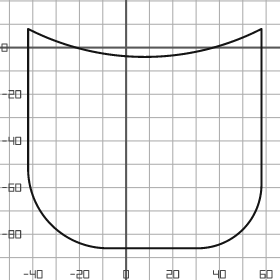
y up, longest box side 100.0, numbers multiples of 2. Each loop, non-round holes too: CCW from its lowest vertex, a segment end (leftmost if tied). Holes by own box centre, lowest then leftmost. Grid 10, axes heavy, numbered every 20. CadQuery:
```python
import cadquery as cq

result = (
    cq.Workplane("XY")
    .moveTo(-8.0, -86.0)
    .lineTo(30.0, -86.0)
    .threePointArc((50.0, -78.0), (58.0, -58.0))
    .lineTo(58.0, 8.0)
    .threePointArc((8.0, -4.0), (-42.0, 8.0))
    .lineTo(-42.0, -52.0)
    .threePointArc((-32.0, -76.0), (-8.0, -86.0))
    .close()
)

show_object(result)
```